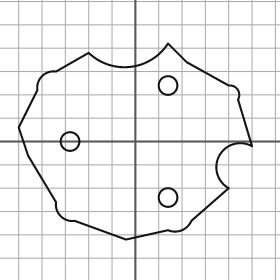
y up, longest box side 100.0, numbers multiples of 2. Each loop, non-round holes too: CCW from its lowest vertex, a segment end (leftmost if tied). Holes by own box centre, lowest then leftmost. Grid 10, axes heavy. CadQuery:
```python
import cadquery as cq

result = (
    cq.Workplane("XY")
    .moveTo(-4.0, -42.0)
    .lineTo(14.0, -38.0)
    .threePointArc((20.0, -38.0), (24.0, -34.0))
    .lineTo(40.0, -20.0)
    .threePointArc((36.0, -6.0), (50.0, -2.0))
    .lineTo(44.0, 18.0)
    .threePointArc((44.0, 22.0), (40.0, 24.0))
    .lineTo(22.0, 34.0)
    .lineTo(14.0, 42.0)
    .threePointArc((-2.0, 32.0), (-20.0, 38.0))
    .lineTo(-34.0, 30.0)
    .threePointArc((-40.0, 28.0), (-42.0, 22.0))
    .lineTo(-50.0, 6.0)
    .lineTo(-46.0, -6.0)
    .lineTo(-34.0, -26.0)
    .threePointArc((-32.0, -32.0), (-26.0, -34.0))
    .close()
    .moveTo(14.0, -24.0)
    .circle(4.0)
    .moveTo(-28.0, 0.0)
    .circle(4.0)
    .moveTo(14.0, 24.0)
    .circle(4.0)
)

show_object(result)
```